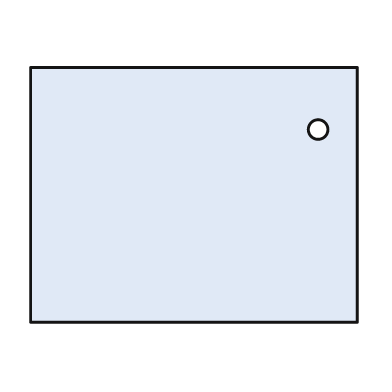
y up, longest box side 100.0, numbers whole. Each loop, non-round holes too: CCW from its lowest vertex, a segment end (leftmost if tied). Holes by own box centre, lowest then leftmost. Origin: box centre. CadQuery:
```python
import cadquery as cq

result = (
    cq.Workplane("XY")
    .moveTo(-50.0, -39.0)
    .lineTo(50.0, -39.0)
    .lineTo(50.0, 39.0)
    .lineTo(-50.0, 39.0)
    .close()
    .moveTo(38.0, 20.0)
    .circle(3.0)
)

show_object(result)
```